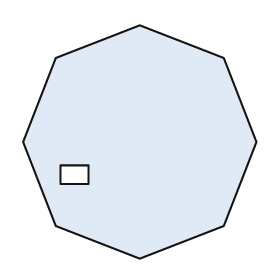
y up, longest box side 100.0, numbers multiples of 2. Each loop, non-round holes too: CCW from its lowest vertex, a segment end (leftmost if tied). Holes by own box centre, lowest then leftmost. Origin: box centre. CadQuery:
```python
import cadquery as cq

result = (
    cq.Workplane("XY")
    .moveTo(0.0, -50.0)
    .lineTo(36.0, -36.0)
    .lineTo(50.0, 0.0)
    .lineTo(36.0, 36.0)
    .lineTo(0.0, 50.0)
    .lineTo(-36.0, 36.0)
    .lineTo(-50.0, 0.0)
    .lineTo(-36.0, -36.0)
    .close()
    .moveTo(-34.0, -18.0)
    .lineTo(-22.0, -18.0)
    .lineTo(-22.0, -10.0)
    .lineTo(-34.0, -10.0)
    .close()
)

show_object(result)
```